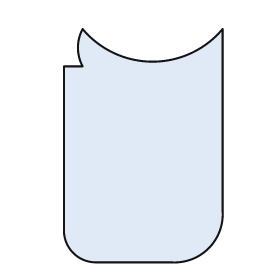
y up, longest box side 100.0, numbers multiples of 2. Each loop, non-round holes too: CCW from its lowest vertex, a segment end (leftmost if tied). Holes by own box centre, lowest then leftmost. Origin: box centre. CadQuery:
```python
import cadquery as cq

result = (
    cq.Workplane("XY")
    .moveTo(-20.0, -50.0)
    .lineTo(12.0, -50.0)
    .threePointArc((28.0, -44.0), (34.0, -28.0))
    .lineTo(34.0, 50.0)
    .threePointArc((4.0, 36.0), (-26.0, 50.0))
    .threePointArc((-28.0, 42.0), (-26.0, 34.0))
    .lineTo(-34.0, 34.0)
    .lineTo(-34.0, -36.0)
    .threePointArc((-30.0, -46.0), (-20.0, -50.0))
    .close()
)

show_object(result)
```